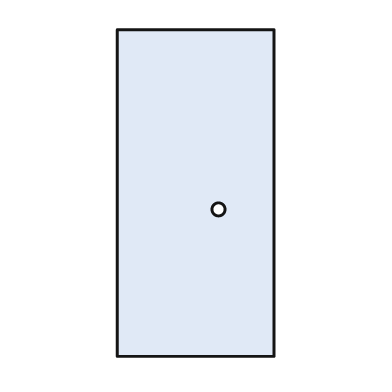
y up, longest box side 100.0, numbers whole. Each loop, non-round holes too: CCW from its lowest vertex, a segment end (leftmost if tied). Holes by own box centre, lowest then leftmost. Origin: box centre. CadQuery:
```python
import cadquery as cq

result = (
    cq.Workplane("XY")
    .moveTo(-24.0, -50.0)
    .lineTo(24.0, -50.0)
    .lineTo(24.0, 50.0)
    .lineTo(-24.0, 50.0)
    .close()
    .moveTo(7.0, -5.0)
    .circle(2.0)
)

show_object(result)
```